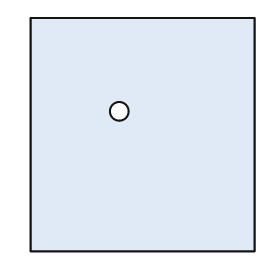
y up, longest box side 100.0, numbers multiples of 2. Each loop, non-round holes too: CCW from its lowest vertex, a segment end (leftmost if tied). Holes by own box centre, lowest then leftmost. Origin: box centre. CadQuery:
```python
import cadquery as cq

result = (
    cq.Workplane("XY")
    .moveTo(-48.0, -50.0)
    .lineTo(48.0, -50.0)
    .lineTo(48.0, 50.0)
    .lineTo(-48.0, 50.0)
    .close()
    .moveTo(-10.0, 10.0)
    .circle(4.0)
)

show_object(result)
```